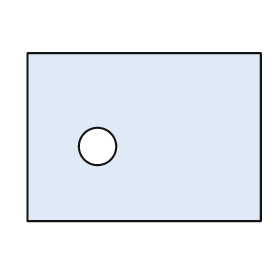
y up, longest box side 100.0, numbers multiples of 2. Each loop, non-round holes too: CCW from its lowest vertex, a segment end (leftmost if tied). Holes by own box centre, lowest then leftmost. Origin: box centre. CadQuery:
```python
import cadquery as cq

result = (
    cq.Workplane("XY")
    .moveTo(-50.0, -36.0)
    .lineTo(50.0, -36.0)
    .lineTo(50.0, 36.0)
    .lineTo(-50.0, 36.0)
    .close()
    .moveTo(-20.0, -4.0)
    .circle(8.0)
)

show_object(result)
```